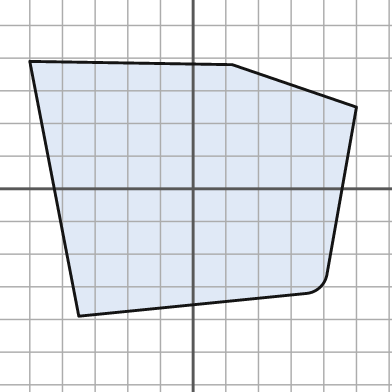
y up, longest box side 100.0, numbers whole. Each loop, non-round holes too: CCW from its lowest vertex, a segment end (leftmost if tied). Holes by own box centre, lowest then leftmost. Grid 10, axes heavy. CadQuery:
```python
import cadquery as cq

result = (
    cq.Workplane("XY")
    .moveTo(-35.0, -39.0)
    .lineTo(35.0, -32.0)
    .threePointArc((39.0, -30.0), (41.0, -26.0))
    .lineTo(50.0, 25.0)
    .lineTo(12.0, 38.0)
    .lineTo(-50.0, 39.0)
    .close()
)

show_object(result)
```